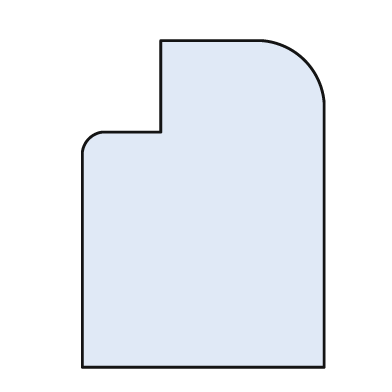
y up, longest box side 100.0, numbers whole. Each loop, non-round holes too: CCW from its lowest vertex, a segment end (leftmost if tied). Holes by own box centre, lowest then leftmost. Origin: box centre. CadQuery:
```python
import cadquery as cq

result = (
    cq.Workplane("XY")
    .moveTo(-37.0, -50.0)
    .lineTo(37.0, -50.0)
    .lineTo(37.0, 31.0)
    .threePointArc((31.0, 44.0), (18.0, 50.0))
    .lineTo(-13.0, 50.0)
    .lineTo(-13.0, 22.0)
    .lineTo(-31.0, 22.0)
    .threePointArc((-35.0, 20.0), (-37.0, 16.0))
    .close()
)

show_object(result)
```